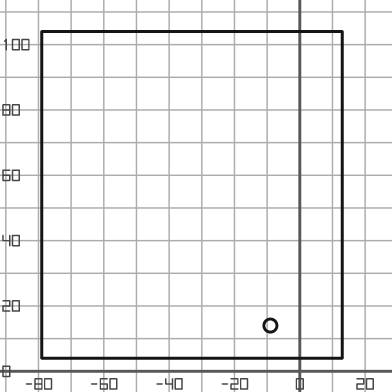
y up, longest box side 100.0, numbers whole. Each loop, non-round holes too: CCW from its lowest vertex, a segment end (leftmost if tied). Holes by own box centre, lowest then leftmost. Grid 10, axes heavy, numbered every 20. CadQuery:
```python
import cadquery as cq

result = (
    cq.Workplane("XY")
    .moveTo(-79.0, 4.0)
    .lineTo(13.0, 4.0)
    .lineTo(13.0, 104.0)
    .lineTo(-79.0, 104.0)
    .close()
    .moveTo(-9.0, 14.0)
    .circle(2.0)
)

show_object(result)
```